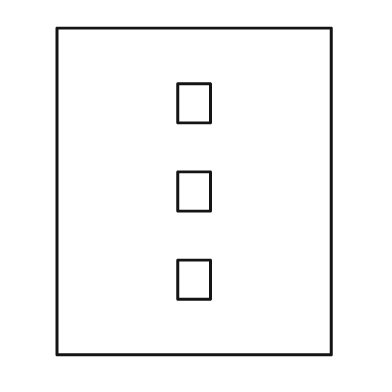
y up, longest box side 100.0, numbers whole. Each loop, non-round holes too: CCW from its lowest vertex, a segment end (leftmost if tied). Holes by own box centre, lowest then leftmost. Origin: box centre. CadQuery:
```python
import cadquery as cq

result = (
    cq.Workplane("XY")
    .moveTo(-42.0, -50.0)
    .lineTo(42.0, -50.0)
    .lineTo(42.0, 50.0)
    .lineTo(-42.0, 50.0)
    .close()
    .moveTo(-5.0, -33.0)
    .lineTo(5.0, -33.0)
    .lineTo(5.0, -21.0)
    .lineTo(-5.0, -21.0)
    .close()
    .moveTo(-5.0, -6.0)
    .lineTo(5.0, -6.0)
    .lineTo(5.0, 6.0)
    .lineTo(-5.0, 6.0)
    .close()
    .moveTo(-5.0, 21.0)
    .lineTo(5.0, 21.0)
    .lineTo(5.0, 33.0)
    .lineTo(-5.0, 33.0)
    .close()
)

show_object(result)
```